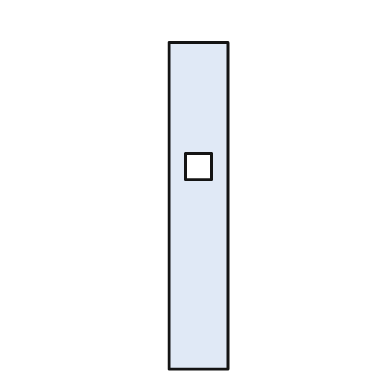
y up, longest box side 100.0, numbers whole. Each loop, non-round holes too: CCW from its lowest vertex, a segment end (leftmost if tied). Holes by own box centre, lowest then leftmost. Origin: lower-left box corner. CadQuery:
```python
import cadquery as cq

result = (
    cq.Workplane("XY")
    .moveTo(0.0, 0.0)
    .lineTo(18.0, 0.0)
    .lineTo(18.0, 100.0)
    .lineTo(0.0, 100.0)
    .close()
    .moveTo(5.0, 58.0)
    .lineTo(13.0, 58.0)
    .lineTo(13.0, 66.0)
    .lineTo(5.0, 66.0)
    .close()
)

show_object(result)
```